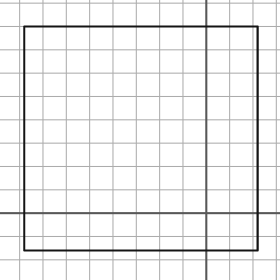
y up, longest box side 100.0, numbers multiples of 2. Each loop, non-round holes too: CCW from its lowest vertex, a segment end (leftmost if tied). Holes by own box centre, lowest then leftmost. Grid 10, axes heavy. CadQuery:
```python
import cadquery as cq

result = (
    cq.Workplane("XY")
    .moveTo(-78.0, -16.0)
    .lineTo(22.0, -16.0)
    .lineTo(22.0, 80.0)
    .lineTo(-78.0, 80.0)
    .close()
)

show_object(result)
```